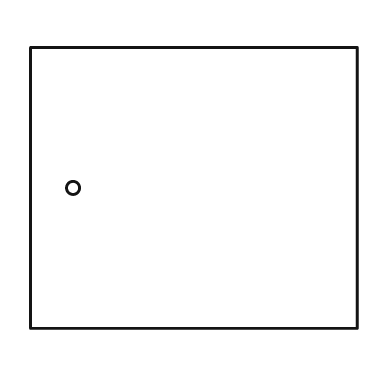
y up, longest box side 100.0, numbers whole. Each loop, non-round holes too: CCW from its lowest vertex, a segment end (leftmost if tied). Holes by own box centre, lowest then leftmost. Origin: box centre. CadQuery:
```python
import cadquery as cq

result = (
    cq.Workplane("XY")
    .moveTo(-50.0, -43.0)
    .lineTo(50.0, -43.0)
    .lineTo(50.0, 43.0)
    .lineTo(-50.0, 43.0)
    .close()
    .moveTo(-37.0, 0.0)
    .circle(2.0)
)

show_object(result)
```